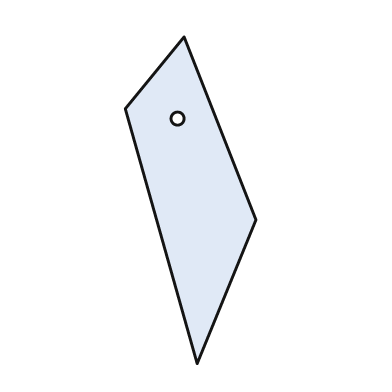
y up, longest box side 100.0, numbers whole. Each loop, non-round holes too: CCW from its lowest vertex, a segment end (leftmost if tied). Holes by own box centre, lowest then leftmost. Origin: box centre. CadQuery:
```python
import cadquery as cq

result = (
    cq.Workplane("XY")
    .moveTo(2.0, -50.0)
    .lineTo(20.0, -6.0)
    .lineTo(-2.0, 50.0)
    .lineTo(-20.0, 28.0)
    .close()
    .moveTo(-4.0, 25.0)
    .circle(2.0)
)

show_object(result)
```